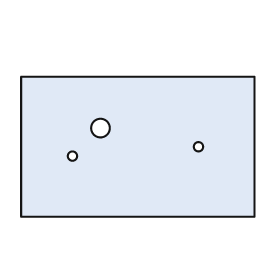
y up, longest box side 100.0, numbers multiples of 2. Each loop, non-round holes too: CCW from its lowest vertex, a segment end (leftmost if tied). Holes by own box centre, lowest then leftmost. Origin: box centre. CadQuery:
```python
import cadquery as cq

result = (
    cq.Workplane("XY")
    .moveTo(-50.0, -30.0)
    .lineTo(50.0, -30.0)
    .lineTo(50.0, 30.0)
    .lineTo(-50.0, 30.0)
    .close()
    .moveTo(-28.0, -4.0)
    .circle(2.0)
    .moveTo(26.0, 0.0)
    .circle(2.0)
    .moveTo(-16.0, 8.0)
    .circle(4.0)
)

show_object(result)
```